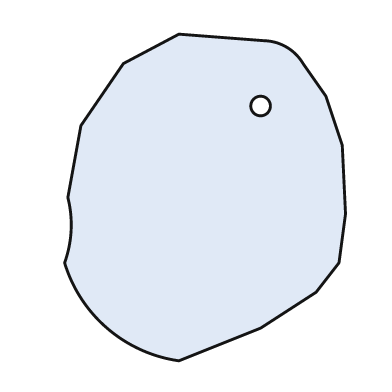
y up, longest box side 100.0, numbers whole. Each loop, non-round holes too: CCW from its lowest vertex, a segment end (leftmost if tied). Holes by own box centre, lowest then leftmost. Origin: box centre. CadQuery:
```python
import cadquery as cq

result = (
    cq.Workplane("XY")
    .moveTo(-8.0, -50.0)
    .lineTo(17.0, -40.0)
    .lineTo(34.0, -29.0)
    .lineTo(41.0, -20.0)
    .lineTo(43.0, -5.0)
    .lineTo(42.0, 16.0)
    .lineTo(37.0, 31.0)
    .lineTo(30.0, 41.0)
    .threePointArc((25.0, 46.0), (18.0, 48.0))
    .lineTo(-8.0, 50.0)
    .lineTo(-25.0, 41.0)
    .lineTo(-38.0, 22.0)
    .lineTo(-42.0, 0.0)
    .threePointArc((-41.0, -10.0), (-43.0, -20.0))
    .threePointArc((-30.0, -40.0), (-8.0, -50.0))
    .close()
    .moveTo(17.0, 28.0)
    .circle(3.0)
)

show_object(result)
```